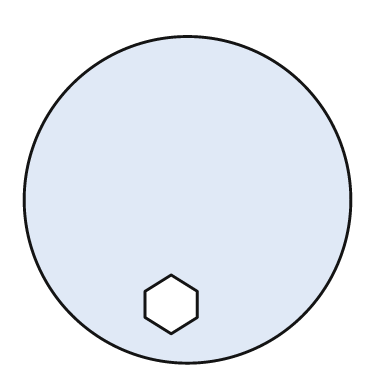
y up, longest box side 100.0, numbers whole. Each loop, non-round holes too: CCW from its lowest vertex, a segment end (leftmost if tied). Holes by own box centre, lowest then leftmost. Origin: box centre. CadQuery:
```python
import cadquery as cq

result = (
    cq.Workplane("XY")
    .moveTo(0.0, 0.0)
    .circle(50.0)
    .moveTo(-5.0, -41.0)
    .lineTo(3.0, -36.0)
    .lineTo(3.0, -28.0)
    .lineTo(-5.0, -23.0)
    .lineTo(-13.0, -28.0)
    .lineTo(-13.0, -36.0)
    .close()
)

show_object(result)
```